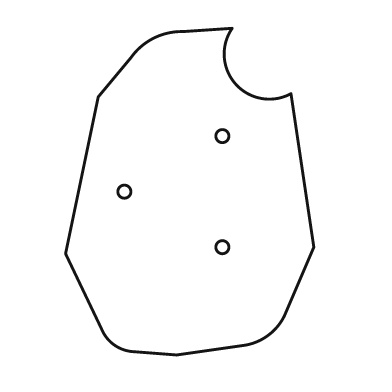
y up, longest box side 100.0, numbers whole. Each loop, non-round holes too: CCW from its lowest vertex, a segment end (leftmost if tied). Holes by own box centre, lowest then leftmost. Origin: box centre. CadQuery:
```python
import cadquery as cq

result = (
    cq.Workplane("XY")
    .moveTo(-4.0, -50.0)
    .lineTo(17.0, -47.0)
    .threePointArc((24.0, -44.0), (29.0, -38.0))
    .lineTo(38.0, -17.0)
    .lineTo(31.0, 30.0)
    .threePointArc((14.0, 33.0), (13.0, 50.0))
    .lineTo(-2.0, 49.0)
    .threePointArc((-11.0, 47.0), (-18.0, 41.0))
    .lineTo(-28.0, 29.0)
    .lineTo(-38.0, -19.0)
    .lineTo(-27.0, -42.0)
    .threePointArc((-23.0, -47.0), (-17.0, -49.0))
    .close()
    .moveTo(10.0, -17.0)
    .circle(2.0)
    .moveTo(-20.0, 0.0)
    .circle(2.0)
    .moveTo(10.0, 17.0)
    .circle(2.0)
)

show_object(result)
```